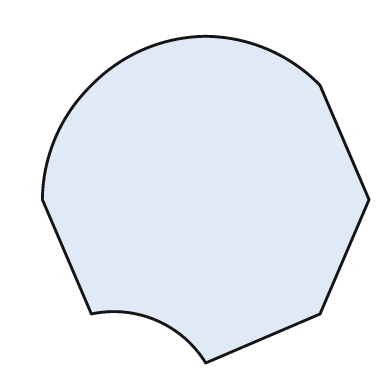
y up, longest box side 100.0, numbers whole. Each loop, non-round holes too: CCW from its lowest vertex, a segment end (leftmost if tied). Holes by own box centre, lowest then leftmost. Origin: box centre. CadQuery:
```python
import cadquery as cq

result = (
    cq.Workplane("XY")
    .moveTo(0.0, -50.0)
    .lineTo(35.0, -35.0)
    .lineTo(50.0, 0.0)
    .lineTo(35.0, 35.0)
    .threePointArc((19.0, 46.0), (0.0, 50.0))
    .threePointArc((-19.0, 46.0), (-35.0, 35.0))
    .threePointArc((-46.0, 19.0), (-50.0, 0.0))
    .lineTo(-35.0, -35.0)
    .threePointArc((-15.0, -37.0), (0.0, -50.0))
    .close()
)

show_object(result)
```